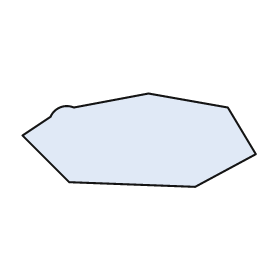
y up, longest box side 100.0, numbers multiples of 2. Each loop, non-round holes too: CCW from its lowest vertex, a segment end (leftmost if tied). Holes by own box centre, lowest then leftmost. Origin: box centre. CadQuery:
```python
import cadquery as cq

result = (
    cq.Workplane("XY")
    .moveTo(24.0, -20.0)
    .lineTo(50.0, -6.0)
    .lineTo(38.0, 14.0)
    .lineTo(4.0, 20.0)
    .lineTo(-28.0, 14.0)
    .threePointArc((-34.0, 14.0), (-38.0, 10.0))
    .lineTo(-50.0, 2.0)
    .lineTo(-30.0, -18.0)
    .close()
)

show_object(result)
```